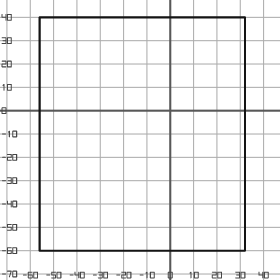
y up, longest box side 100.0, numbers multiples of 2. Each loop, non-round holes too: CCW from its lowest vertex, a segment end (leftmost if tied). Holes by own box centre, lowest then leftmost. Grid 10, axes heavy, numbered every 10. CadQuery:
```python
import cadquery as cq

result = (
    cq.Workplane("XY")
    .moveTo(-56.0, -60.0)
    .lineTo(32.0, -60.0)
    .lineTo(32.0, 40.0)
    .lineTo(-56.0, 40.0)
    .close()
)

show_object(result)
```